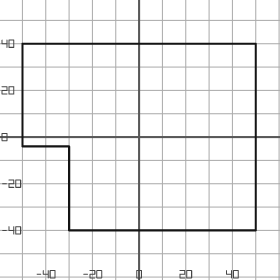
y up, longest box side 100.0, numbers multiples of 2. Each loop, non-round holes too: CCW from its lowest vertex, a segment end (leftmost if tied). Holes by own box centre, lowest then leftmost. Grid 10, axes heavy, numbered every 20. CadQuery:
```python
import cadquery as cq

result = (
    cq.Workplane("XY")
    .moveTo(-30.0, -40.0)
    .lineTo(50.0, -40.0)
    .lineTo(50.0, 40.0)
    .lineTo(-50.0, 40.0)
    .lineTo(-50.0, -4.0)
    .lineTo(-30.0, -4.0)
    .close()
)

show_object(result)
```